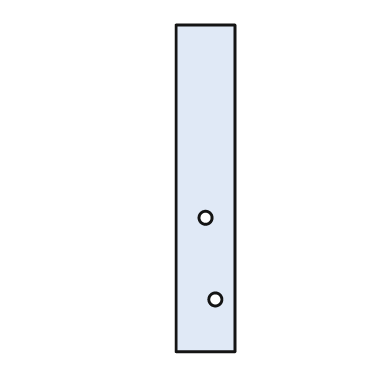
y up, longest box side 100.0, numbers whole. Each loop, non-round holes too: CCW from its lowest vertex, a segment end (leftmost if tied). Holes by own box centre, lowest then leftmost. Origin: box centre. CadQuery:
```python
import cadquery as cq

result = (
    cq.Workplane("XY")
    .moveTo(-9.0, -50.0)
    .lineTo(9.0, -50.0)
    .lineTo(9.0, 50.0)
    .lineTo(-9.0, 50.0)
    .close()
    .moveTo(3.0, -34.0)
    .circle(2.0)
    .moveTo(0.0, -9.0)
    .circle(2.0)
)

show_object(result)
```